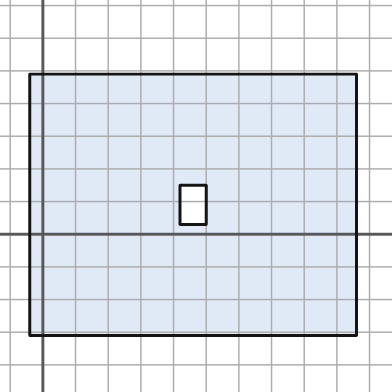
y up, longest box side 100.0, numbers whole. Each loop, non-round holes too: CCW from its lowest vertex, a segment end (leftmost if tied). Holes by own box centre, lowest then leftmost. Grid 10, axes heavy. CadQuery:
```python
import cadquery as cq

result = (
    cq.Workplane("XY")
    .moveTo(-4.0, -31.0)
    .lineTo(96.0, -31.0)
    .lineTo(96.0, 49.0)
    .lineTo(-4.0, 49.0)
    .close()
    .moveTo(42.0, 3.0)
    .lineTo(50.0, 3.0)
    .lineTo(50.0, 15.0)
    .lineTo(42.0, 15.0)
    .close()
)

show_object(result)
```